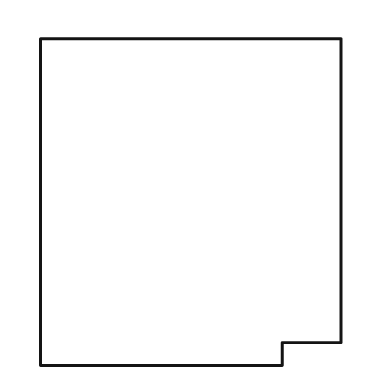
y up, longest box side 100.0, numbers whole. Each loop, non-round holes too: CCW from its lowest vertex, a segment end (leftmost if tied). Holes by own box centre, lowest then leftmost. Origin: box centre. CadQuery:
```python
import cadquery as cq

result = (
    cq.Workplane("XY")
    .moveTo(-46.0, -50.0)
    .lineTo(28.0, -50.0)
    .lineTo(28.0, -43.0)
    .lineTo(46.0, -43.0)
    .lineTo(46.0, 50.0)
    .lineTo(-46.0, 50.0)
    .close()
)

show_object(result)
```